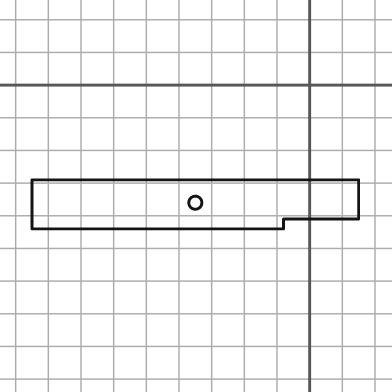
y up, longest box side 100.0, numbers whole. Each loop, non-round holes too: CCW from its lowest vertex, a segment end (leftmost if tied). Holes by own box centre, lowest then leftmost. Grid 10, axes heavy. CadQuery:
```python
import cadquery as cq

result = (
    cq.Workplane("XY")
    .moveTo(-85.0, -44.0)
    .lineTo(-8.0, -44.0)
    .lineTo(-8.0, -41.0)
    .lineTo(15.0, -41.0)
    .lineTo(15.0, -29.0)
    .lineTo(-85.0, -29.0)
    .close()
    .moveTo(-35.0, -36.0)
    .circle(2.0)
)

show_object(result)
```